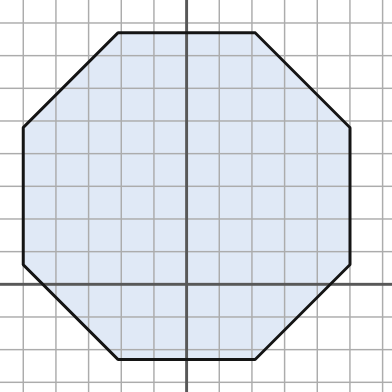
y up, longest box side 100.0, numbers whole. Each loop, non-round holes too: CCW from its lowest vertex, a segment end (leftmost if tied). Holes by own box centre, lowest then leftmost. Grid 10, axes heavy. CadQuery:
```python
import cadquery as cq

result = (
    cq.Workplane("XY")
    .moveTo(-21.0, -23.0)
    .lineTo(21.0, -23.0)
    .lineTo(50.0, 6.0)
    .lineTo(50.0, 48.0)
    .lineTo(21.0, 77.0)
    .lineTo(-21.0, 77.0)
    .lineTo(-50.0, 48.0)
    .lineTo(-50.0, 6.0)
    .close()
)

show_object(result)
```